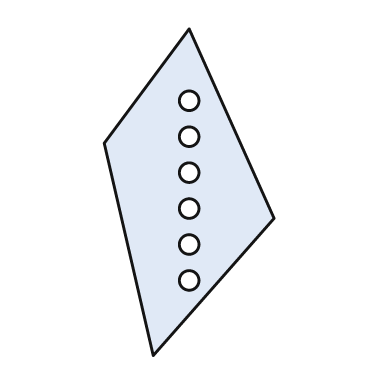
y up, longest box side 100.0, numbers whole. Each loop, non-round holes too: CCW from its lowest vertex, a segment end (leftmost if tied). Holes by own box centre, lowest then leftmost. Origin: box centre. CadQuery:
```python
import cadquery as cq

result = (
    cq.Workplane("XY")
    .moveTo(-11.0, -50.0)
    .lineTo(26.0, -8.0)
    .lineTo(0.0, 50.0)
    .lineTo(-26.0, 15.0)
    .close()
    .moveTo(0.0, -27.0)
    .circle(3.0)
    .moveTo(0.0, -16.0)
    .circle(3.0)
    .moveTo(0.0, -5.0)
    .circle(3.0)
    .moveTo(0.0, 6.0)
    .circle(3.0)
    .moveTo(0.0, 17.0)
    .circle(3.0)
    .moveTo(0.0, 28.0)
    .circle(3.0)
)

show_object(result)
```